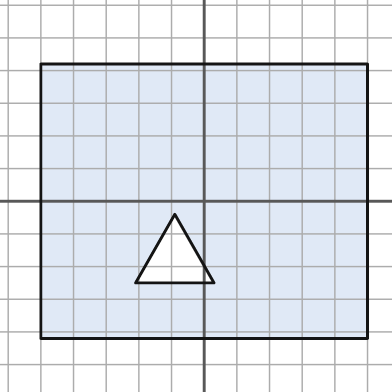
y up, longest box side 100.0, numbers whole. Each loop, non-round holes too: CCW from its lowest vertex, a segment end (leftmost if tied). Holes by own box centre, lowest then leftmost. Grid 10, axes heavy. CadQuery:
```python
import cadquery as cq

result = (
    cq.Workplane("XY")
    .moveTo(-50.0, -42.0)
    .lineTo(50.0, -42.0)
    .lineTo(50.0, 42.0)
    .lineTo(-50.0, 42.0)
    .close()
    .moveTo(-21.0, -25.0)
    .lineTo(3.0, -25.0)
    .lineTo(-9.0, -4.0)
    .close()
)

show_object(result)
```